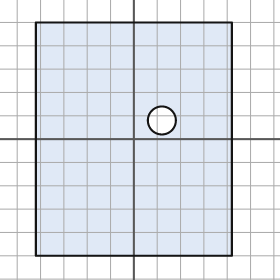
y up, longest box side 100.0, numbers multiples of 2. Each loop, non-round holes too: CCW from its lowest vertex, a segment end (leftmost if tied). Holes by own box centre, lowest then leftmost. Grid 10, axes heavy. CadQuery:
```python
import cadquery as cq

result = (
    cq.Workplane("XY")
    .moveTo(-42.0, -50.0)
    .lineTo(42.0, -50.0)
    .lineTo(42.0, 50.0)
    .lineTo(-42.0, 50.0)
    .close()
    .moveTo(12.0, 8.0)
    .circle(6.0)
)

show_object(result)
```